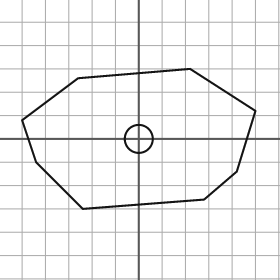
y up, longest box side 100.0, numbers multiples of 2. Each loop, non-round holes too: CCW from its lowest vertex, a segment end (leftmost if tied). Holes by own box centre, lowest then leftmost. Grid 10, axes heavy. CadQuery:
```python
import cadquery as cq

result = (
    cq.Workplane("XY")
    .moveTo(-24.0, -30.0)
    .lineTo(28.0, -26.0)
    .lineTo(42.0, -14.0)
    .lineTo(50.0, 12.0)
    .lineTo(22.0, 30.0)
    .lineTo(-26.0, 26.0)
    .lineTo(-50.0, 8.0)
    .lineTo(-44.0, -10.0)
    .close()
    .moveTo(0.0, 0.0)
    .circle(6.0)
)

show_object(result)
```